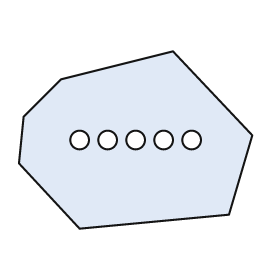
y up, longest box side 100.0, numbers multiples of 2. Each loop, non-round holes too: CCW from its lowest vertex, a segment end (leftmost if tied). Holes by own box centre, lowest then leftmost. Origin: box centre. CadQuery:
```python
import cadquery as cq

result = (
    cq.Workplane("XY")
    .moveTo(-24.0, -38.0)
    .lineTo(40.0, -32.0)
    .lineTo(50.0, 2.0)
    .lineTo(16.0, 38.0)
    .lineTo(-32.0, 26.0)
    .lineTo(-48.0, 10.0)
    .lineTo(-50.0, -10.0)
    .close()
    .moveTo(-24.0, 0.0)
    .circle(4.0)
    .moveTo(-12.0, 0.0)
    .circle(4.0)
    .moveTo(0.0, 0.0)
    .circle(4.0)
    .moveTo(12.0, 0.0)
    .circle(4.0)
    .moveTo(24.0, 0.0)
    .circle(4.0)
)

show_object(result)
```